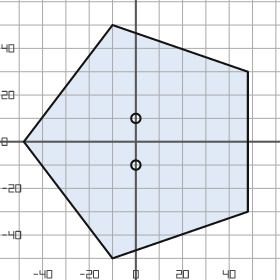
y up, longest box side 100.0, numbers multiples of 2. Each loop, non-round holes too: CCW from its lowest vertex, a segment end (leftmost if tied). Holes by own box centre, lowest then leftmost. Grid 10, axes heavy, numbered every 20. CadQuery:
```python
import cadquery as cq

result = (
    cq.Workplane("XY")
    .moveTo(-10.0, -50.0)
    .lineTo(48.0, -30.0)
    .lineTo(48.0, 30.0)
    .lineTo(-10.0, 50.0)
    .lineTo(-48.0, 0.0)
    .close()
    .moveTo(0.0, -10.0)
    .circle(2.0)
    .moveTo(0.0, 10.0)
    .circle(2.0)
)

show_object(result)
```